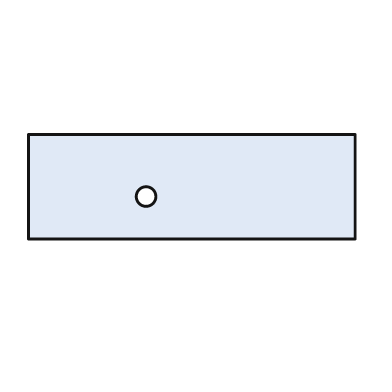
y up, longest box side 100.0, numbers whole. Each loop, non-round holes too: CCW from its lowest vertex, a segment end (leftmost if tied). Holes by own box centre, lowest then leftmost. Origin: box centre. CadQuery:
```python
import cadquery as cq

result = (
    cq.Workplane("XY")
    .moveTo(-50.0, -16.0)
    .lineTo(50.0, -16.0)
    .lineTo(50.0, 16.0)
    .lineTo(-50.0, 16.0)
    .close()
    .moveTo(-14.0, -3.0)
    .circle(3.0)
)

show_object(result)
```